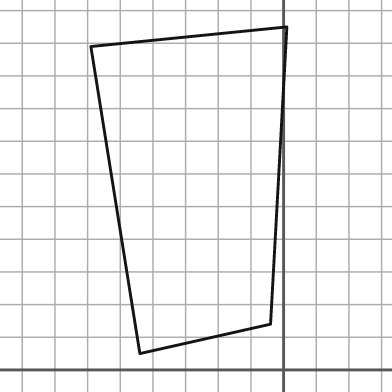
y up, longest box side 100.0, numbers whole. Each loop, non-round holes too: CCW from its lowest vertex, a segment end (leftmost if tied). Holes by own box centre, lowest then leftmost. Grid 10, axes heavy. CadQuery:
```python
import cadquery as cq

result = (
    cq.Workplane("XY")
    .moveTo(-44.0, 5.0)
    .lineTo(-4.0, 14.0)
    .lineTo(1.0, 105.0)
    .lineTo(-59.0, 99.0)
    .close()
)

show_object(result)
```